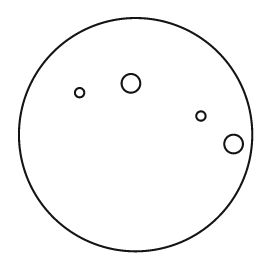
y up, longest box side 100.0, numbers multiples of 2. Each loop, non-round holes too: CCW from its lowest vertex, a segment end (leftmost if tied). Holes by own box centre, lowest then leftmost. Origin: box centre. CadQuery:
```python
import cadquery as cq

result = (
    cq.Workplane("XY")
    .moveTo(0.0, 0.0)
    .circle(50.0)
    .moveTo(42.0, -4.0)
    .circle(4.0)
    .moveTo(28.0, 8.0)
    .circle(2.0)
    .moveTo(-24.0, 18.0)
    .circle(2.0)
    .moveTo(-2.0, 22.0)
    .circle(4.0)
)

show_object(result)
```